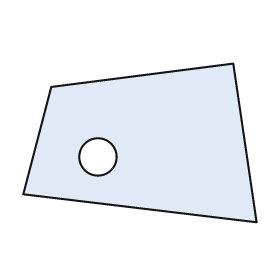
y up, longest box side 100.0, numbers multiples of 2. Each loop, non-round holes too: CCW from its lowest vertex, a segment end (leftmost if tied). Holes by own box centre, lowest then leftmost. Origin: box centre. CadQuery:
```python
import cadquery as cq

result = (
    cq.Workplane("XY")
    .moveTo(50.0, -34.0)
    .lineTo(40.0, 34.0)
    .lineTo(-38.0, 24.0)
    .lineTo(-50.0, -22.0)
    .close()
    .moveTo(-18.0, -6.0)
    .circle(8.0)
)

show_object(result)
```